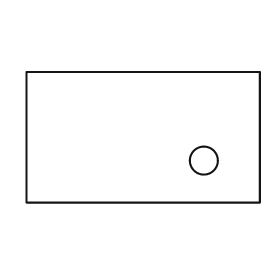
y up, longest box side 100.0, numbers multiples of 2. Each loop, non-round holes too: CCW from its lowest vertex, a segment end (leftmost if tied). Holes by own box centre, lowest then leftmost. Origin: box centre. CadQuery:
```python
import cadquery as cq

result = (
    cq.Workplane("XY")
    .moveTo(-50.0, -28.0)
    .lineTo(50.0, -28.0)
    .lineTo(50.0, 28.0)
    .lineTo(-50.0, 28.0)
    .close()
    .moveTo(26.0, -10.0)
    .circle(6.0)
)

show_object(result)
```